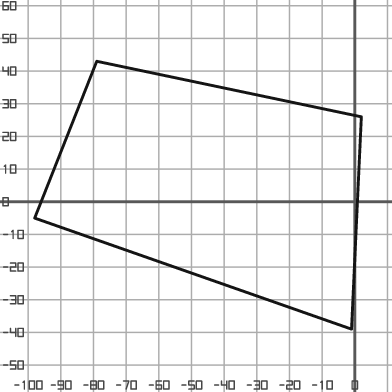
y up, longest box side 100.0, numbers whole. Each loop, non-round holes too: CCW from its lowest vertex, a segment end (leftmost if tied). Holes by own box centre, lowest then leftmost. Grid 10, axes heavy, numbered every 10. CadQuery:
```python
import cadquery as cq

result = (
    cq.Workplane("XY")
    .moveTo(-1.0, -39.0)
    .lineTo(2.0, 26.0)
    .lineTo(-79.0, 43.0)
    .lineTo(-98.0, -5.0)
    .close()
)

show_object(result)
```